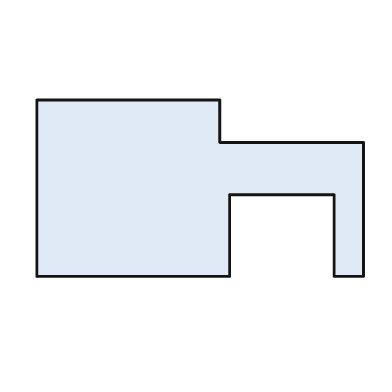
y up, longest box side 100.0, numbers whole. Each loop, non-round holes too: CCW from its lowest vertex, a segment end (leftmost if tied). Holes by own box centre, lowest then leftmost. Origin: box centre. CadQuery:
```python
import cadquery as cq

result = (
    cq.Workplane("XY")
    .moveTo(-50.0, -27.0)
    .lineTo(9.0, -27.0)
    .lineTo(9.0, -2.0)
    .lineTo(41.0, -2.0)
    .lineTo(41.0, -27.0)
    .lineTo(50.0, -27.0)
    .lineTo(50.0, 14.0)
    .lineTo(6.0, 14.0)
    .lineTo(6.0, 27.0)
    .lineTo(-50.0, 27.0)
    .close()
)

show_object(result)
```